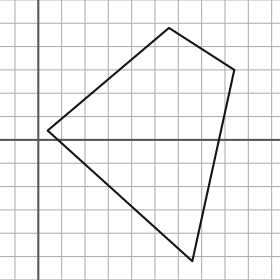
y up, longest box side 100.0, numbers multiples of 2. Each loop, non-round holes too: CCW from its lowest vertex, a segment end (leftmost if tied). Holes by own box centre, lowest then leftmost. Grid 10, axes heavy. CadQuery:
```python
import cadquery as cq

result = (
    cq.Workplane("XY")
    .moveTo(66.0, -52.0)
    .lineTo(84.0, 30.0)
    .lineTo(56.0, 48.0)
    .lineTo(4.0, 4.0)
    .close()
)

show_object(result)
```